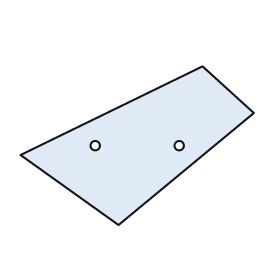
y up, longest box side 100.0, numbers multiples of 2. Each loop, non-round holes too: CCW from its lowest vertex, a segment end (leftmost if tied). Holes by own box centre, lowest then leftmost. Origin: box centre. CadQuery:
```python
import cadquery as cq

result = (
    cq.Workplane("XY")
    .moveTo(-8.0, -34.0)
    .lineTo(50.0, 14.0)
    .lineTo(28.0, 34.0)
    .lineTo(-50.0, -4.0)
    .close()
    .moveTo(-18.0, 0.0)
    .circle(2.0)
    .moveTo(18.0, 0.0)
    .circle(2.0)
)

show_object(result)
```